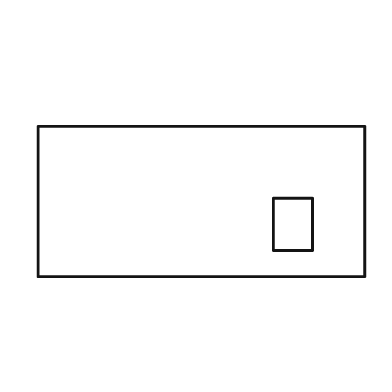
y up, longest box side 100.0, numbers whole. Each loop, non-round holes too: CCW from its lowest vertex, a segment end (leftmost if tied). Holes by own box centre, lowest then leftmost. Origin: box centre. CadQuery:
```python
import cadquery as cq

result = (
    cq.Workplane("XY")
    .moveTo(-50.0, -23.0)
    .lineTo(50.0, -23.0)
    .lineTo(50.0, 23.0)
    .lineTo(-50.0, 23.0)
    .close()
    .moveTo(22.0, -15.0)
    .lineTo(34.0, -15.0)
    .lineTo(34.0, 1.0)
    .lineTo(22.0, 1.0)
    .close()
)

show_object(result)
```